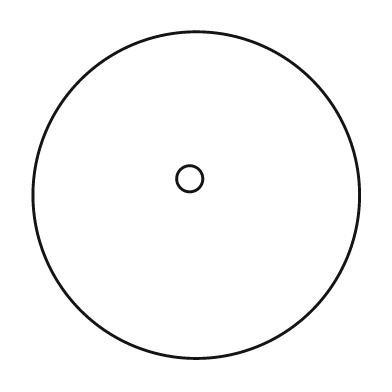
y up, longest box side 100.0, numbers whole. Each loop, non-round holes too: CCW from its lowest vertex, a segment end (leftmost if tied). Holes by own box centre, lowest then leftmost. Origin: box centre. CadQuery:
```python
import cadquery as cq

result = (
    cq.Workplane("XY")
    .moveTo(0.0, 0.0)
    .circle(50.0)
    .moveTo(-2.0, 5.0)
    .circle(4.0)
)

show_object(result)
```